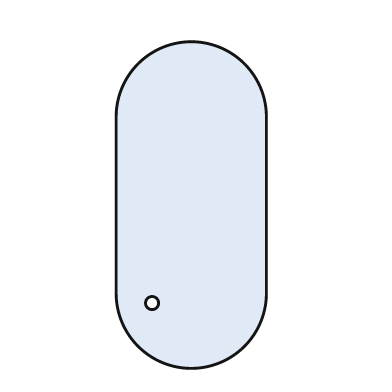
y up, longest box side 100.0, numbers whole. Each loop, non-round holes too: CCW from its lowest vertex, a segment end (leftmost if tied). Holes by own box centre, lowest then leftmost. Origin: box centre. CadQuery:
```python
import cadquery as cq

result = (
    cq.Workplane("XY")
    .moveTo(-23.0, -27.0)
    .threePointArc((0.0, -50.0), (23.0, -27.0))
    .lineTo(23.0, 27.0)
    .threePointArc((0.0, 50.0), (-23.0, 27.0))
    .close()
    .moveTo(-12.0, -30.0)
    .circle(2.0)
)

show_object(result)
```